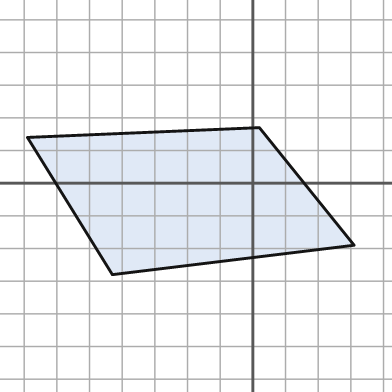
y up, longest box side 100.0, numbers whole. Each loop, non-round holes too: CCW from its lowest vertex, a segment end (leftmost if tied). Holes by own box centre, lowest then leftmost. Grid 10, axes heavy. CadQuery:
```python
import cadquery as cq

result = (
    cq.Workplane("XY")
    .moveTo(-43.0, -28.0)
    .lineTo(31.0, -19.0)
    .lineTo(2.0, 17.0)
    .lineTo(-69.0, 14.0)
    .close()
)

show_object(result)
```